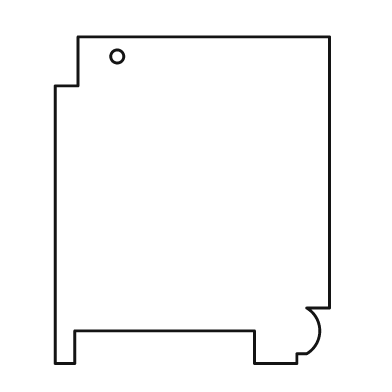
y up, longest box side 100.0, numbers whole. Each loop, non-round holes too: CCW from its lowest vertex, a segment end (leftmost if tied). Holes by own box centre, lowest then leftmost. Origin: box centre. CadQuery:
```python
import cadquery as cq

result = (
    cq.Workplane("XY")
    .moveTo(-42.0, -50.0)
    .lineTo(-36.0, -50.0)
    .lineTo(-36.0, -40.0)
    .lineTo(19.0, -40.0)
    .lineTo(19.0, -50.0)
    .lineTo(32.0, -50.0)
    .lineTo(32.0, -47.0)
    .lineTo(35.0, -47.0)
    .threePointArc((39.0, -40.0), (35.0, -33.0))
    .lineTo(42.0, -33.0)
    .lineTo(42.0, 50.0)
    .lineTo(-35.0, 50.0)
    .lineTo(-35.0, 35.0)
    .lineTo(-42.0, 35.0)
    .close()
    .moveTo(-23.0, 44.0)
    .circle(2.0)
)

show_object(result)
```